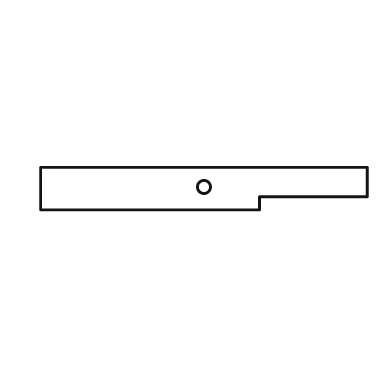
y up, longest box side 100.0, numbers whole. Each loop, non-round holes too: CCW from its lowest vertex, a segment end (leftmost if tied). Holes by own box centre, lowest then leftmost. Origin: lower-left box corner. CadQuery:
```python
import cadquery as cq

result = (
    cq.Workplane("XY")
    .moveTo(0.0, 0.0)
    .lineTo(67.0, 0.0)
    .lineTo(67.0, 4.0)
    .lineTo(100.0, 4.0)
    .lineTo(100.0, 13.0)
    .lineTo(0.0, 13.0)
    .close()
    .moveTo(50.0, 7.0)
    .circle(2.0)
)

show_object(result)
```